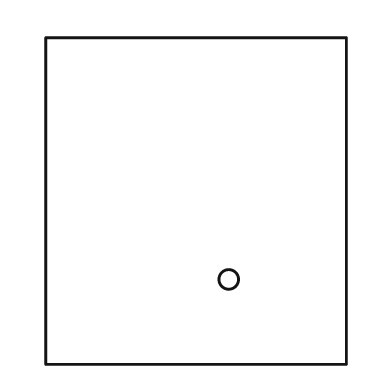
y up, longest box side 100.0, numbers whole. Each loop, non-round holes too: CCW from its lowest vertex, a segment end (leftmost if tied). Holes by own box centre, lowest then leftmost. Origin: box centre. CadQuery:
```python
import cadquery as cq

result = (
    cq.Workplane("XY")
    .moveTo(-46.0, -50.0)
    .lineTo(46.0, -50.0)
    .lineTo(46.0, 50.0)
    .lineTo(-46.0, 50.0)
    .close()
    .moveTo(10.0, -24.0)
    .circle(3.0)
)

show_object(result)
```